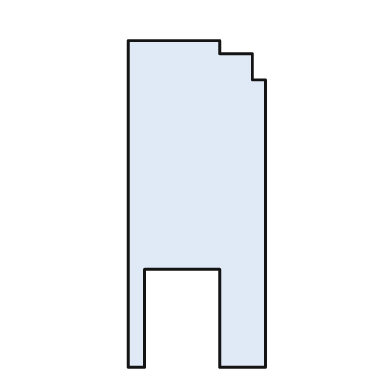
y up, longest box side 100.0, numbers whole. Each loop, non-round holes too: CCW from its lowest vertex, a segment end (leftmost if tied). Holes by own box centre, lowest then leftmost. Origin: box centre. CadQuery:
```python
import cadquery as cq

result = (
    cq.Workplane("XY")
    .moveTo(-21.0, -50.0)
    .lineTo(-16.0, -50.0)
    .lineTo(-16.0, -20.0)
    .lineTo(7.0, -20.0)
    .lineTo(7.0, -50.0)
    .lineTo(21.0, -50.0)
    .lineTo(21.0, 38.0)
    .lineTo(17.0, 38.0)
    .lineTo(17.0, 46.0)
    .lineTo(7.0, 46.0)
    .lineTo(7.0, 50.0)
    .lineTo(-21.0, 50.0)
    .close()
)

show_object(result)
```